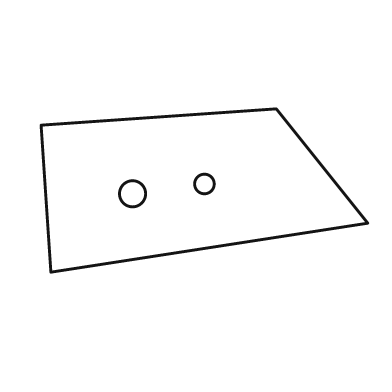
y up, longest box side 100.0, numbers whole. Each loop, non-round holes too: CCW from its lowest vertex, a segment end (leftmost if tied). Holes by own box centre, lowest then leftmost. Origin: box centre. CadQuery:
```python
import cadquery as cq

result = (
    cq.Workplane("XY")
    .moveTo(-47.0, -25.0)
    .lineTo(50.0, -10.0)
    .lineTo(22.0, 25.0)
    .lineTo(-50.0, 20.0)
    .close()
    .moveTo(-22.0, -1.0)
    .circle(4.0)
    .moveTo(0.0, 2.0)
    .circle(3.0)
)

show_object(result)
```